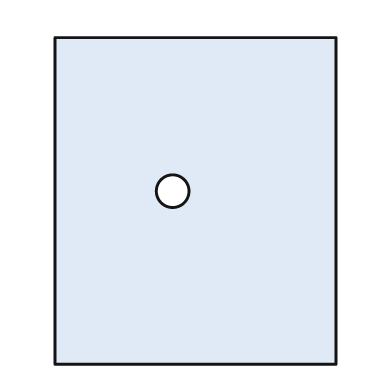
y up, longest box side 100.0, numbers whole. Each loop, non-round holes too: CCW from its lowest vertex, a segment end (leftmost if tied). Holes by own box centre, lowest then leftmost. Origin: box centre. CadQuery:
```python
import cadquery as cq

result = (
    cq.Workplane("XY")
    .moveTo(-43.0, -50.0)
    .lineTo(43.0, -50.0)
    .lineTo(43.0, 50.0)
    .lineTo(-43.0, 50.0)
    .close()
    .moveTo(-7.0, 3.0)
    .circle(5.0)
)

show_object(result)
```